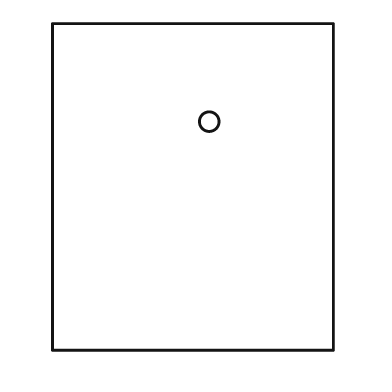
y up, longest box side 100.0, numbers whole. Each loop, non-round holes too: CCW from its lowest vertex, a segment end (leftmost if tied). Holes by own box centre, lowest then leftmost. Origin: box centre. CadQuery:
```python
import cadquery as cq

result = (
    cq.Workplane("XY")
    .moveTo(-43.0, -50.0)
    .lineTo(43.0, -50.0)
    .lineTo(43.0, 50.0)
    .lineTo(-43.0, 50.0)
    .close()
    .moveTo(5.0, 20.0)
    .circle(3.0)
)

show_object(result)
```